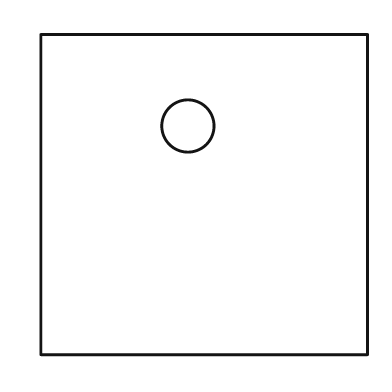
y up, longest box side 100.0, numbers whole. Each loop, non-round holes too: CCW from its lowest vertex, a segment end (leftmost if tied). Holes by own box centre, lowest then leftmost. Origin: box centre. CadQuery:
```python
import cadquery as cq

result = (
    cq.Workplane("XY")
    .moveTo(-50.0, -49.0)
    .lineTo(50.0, -49.0)
    .lineTo(50.0, 49.0)
    .lineTo(-50.0, 49.0)
    .close()
    .moveTo(-5.0, 21.0)
    .circle(8.0)
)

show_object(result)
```